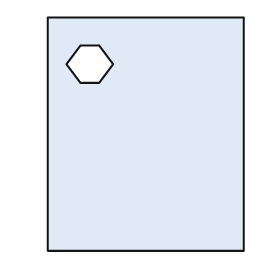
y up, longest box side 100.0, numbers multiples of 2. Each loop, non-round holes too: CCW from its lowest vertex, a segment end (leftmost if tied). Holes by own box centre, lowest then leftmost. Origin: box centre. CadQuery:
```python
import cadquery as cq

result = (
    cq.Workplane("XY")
    .moveTo(-42.0, -50.0)
    .lineTo(42.0, -50.0)
    .lineTo(42.0, 50.0)
    .lineTo(-42.0, 50.0)
    .close()
    .moveTo(-28.0, 22.0)
    .lineTo(-20.0, 22.0)
    .lineTo(-14.0, 30.0)
    .lineTo(-20.0, 38.0)
    .lineTo(-28.0, 38.0)
    .lineTo(-34.0, 30.0)
    .close()
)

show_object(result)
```